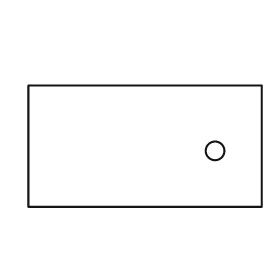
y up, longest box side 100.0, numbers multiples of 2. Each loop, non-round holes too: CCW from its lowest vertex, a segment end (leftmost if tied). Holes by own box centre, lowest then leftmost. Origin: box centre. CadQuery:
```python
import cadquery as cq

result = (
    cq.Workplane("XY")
    .moveTo(-50.0, -26.0)
    .lineTo(50.0, -26.0)
    .lineTo(50.0, 26.0)
    .lineTo(-50.0, 26.0)
    .close()
    .moveTo(30.0, -2.0)
    .circle(4.0)
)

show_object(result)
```